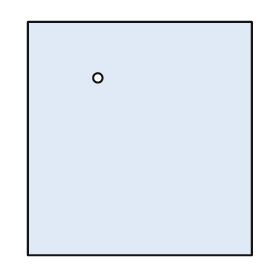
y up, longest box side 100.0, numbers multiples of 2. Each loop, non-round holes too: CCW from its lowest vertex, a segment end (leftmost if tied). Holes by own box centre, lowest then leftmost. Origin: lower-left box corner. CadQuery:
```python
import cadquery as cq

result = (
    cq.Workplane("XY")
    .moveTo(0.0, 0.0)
    .lineTo(96.0, 0.0)
    .lineTo(96.0, 100.0)
    .lineTo(0.0, 100.0)
    .close()
    .moveTo(30.0, 76.0)
    .circle(2.0)
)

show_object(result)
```